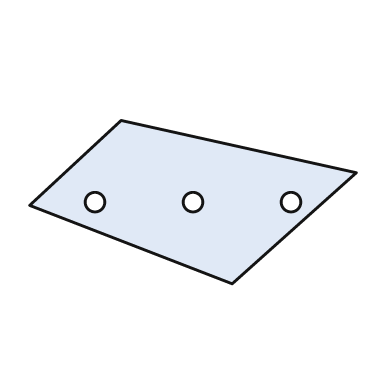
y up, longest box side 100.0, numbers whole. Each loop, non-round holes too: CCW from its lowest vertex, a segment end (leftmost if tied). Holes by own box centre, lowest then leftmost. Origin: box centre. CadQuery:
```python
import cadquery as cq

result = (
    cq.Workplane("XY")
    .moveTo(12.0, -25.0)
    .lineTo(50.0, 9.0)
    .lineTo(-22.0, 25.0)
    .lineTo(-50.0, -1.0)
    .close()
    .moveTo(-30.0, 0.0)
    .circle(3.0)
    .moveTo(0.0, 0.0)
    .circle(3.0)
    .moveTo(30.0, 0.0)
    .circle(3.0)
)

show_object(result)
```